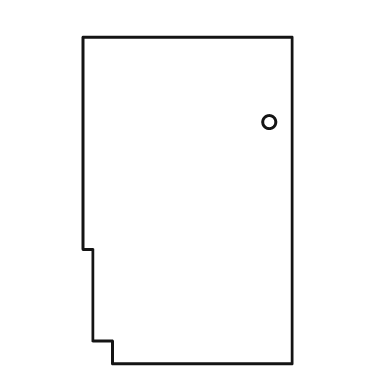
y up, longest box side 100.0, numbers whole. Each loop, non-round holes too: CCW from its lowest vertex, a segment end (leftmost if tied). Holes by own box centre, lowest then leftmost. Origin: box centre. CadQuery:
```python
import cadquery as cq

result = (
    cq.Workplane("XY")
    .moveTo(-23.0, -50.0)
    .lineTo(32.0, -50.0)
    .lineTo(32.0, 50.0)
    .lineTo(-32.0, 50.0)
    .lineTo(-32.0, -15.0)
    .lineTo(-29.0, -15.0)
    .lineTo(-29.0, -43.0)
    .lineTo(-23.0, -43.0)
    .close()
    .moveTo(25.0, 24.0)
    .circle(2.0)
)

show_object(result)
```